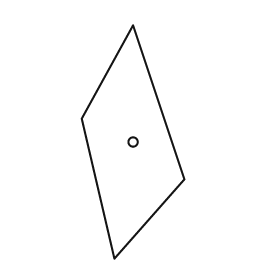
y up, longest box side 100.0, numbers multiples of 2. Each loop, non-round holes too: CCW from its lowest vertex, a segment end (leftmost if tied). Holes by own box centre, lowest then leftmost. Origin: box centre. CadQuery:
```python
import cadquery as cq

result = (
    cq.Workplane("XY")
    .moveTo(-8.0, -50.0)
    .lineTo(22.0, -16.0)
    .lineTo(0.0, 50.0)
    .lineTo(-22.0, 10.0)
    .close()
    .moveTo(0.0, 0.0)
    .circle(2.0)
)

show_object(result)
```